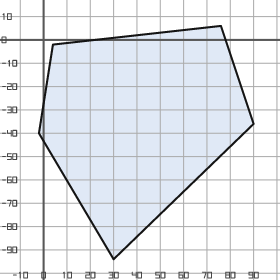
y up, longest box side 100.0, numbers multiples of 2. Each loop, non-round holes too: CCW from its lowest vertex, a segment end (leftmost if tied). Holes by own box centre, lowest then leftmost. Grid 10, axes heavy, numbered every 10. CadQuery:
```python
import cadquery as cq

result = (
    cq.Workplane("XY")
    .moveTo(30.0, -94.0)
    .lineTo(90.0, -36.0)
    .lineTo(76.0, 6.0)
    .lineTo(4.0, -2.0)
    .lineTo(-2.0, -40.0)
    .close()
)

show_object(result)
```